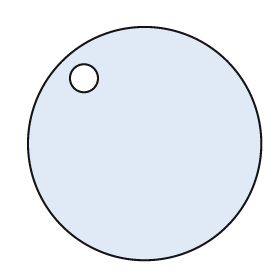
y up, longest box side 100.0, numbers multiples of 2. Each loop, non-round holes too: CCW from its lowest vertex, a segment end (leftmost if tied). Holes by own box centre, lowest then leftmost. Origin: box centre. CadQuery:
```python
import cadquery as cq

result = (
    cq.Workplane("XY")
    .moveTo(0.0, 0.0)
    .circle(50.0)
    .moveTo(-26.0, 28.0)
    .circle(6.0)
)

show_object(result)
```